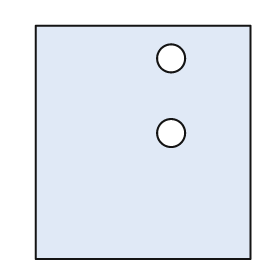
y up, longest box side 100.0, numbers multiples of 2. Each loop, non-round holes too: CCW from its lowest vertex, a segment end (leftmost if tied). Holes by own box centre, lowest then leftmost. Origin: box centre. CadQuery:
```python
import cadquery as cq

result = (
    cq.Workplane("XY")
    .moveTo(-46.0, -50.0)
    .lineTo(46.0, -50.0)
    .lineTo(46.0, 50.0)
    .lineTo(-46.0, 50.0)
    .close()
    .moveTo(12.0, 4.0)
    .circle(6.0)
    .moveTo(12.0, 36.0)
    .circle(6.0)
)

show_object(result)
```